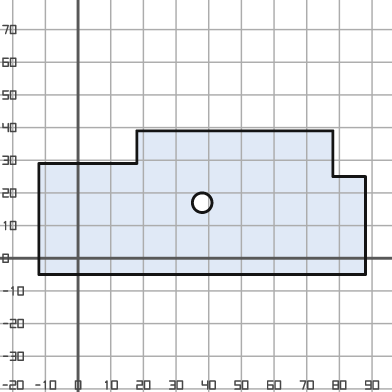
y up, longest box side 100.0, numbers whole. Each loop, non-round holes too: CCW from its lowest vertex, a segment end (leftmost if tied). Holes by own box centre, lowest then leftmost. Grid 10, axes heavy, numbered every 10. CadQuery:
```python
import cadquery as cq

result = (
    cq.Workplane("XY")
    .moveTo(-12.0, -5.0)
    .lineTo(88.0, -5.0)
    .lineTo(88.0, 25.0)
    .lineTo(78.0, 25.0)
    .lineTo(78.0, 39.0)
    .lineTo(18.0, 39.0)
    .lineTo(18.0, 29.0)
    .lineTo(-12.0, 29.0)
    .close()
    .moveTo(38.0, 17.0)
    .circle(3.0)
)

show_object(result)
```